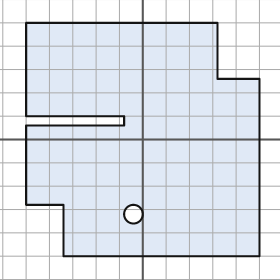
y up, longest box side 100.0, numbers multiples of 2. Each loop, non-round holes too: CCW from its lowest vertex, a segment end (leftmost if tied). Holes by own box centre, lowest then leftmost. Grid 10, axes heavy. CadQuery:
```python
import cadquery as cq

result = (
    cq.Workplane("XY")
    .moveTo(-34.0, -50.0)
    .lineTo(50.0, -50.0)
    .lineTo(50.0, 26.0)
    .lineTo(32.0, 26.0)
    .lineTo(32.0, 50.0)
    .lineTo(-50.0, 50.0)
    .lineTo(-50.0, 10.0)
    .lineTo(-8.0, 10.0)
    .lineTo(-8.0, 6.0)
    .lineTo(-50.0, 6.0)
    .lineTo(-50.0, -28.0)
    .lineTo(-34.0, -28.0)
    .close()
    .moveTo(-4.0, -32.0)
    .circle(4.0)
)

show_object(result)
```